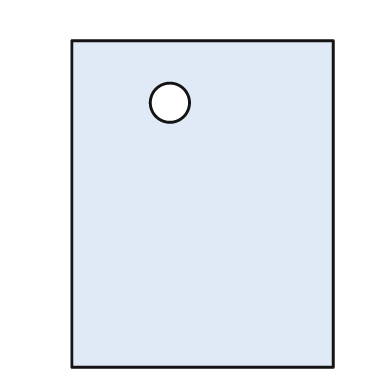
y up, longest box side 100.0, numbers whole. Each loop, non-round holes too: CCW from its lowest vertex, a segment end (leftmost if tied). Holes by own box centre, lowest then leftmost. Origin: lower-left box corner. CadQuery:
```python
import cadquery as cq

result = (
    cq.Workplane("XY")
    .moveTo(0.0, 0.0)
    .lineTo(80.0, 0.0)
    .lineTo(80.0, 100.0)
    .lineTo(0.0, 100.0)
    .close()
    .moveTo(30.0, 81.0)
    .circle(6.0)
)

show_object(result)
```